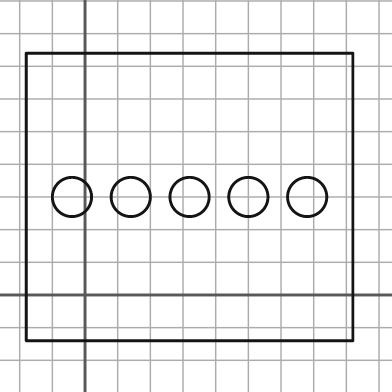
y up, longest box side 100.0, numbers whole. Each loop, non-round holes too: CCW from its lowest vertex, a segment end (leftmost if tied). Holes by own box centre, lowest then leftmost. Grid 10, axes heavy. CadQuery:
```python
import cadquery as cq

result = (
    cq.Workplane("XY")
    .moveTo(-18.0, -14.0)
    .lineTo(82.0, -14.0)
    .lineTo(82.0, 74.0)
    .lineTo(-18.0, 74.0)
    .close()
    .moveTo(-4.0, 30.0)
    .circle(6.0)
    .moveTo(14.0, 30.0)
    .circle(6.0)
    .moveTo(32.0, 30.0)
    .circle(6.0)
    .moveTo(50.0, 30.0)
    .circle(6.0)
    .moveTo(68.0, 30.0)
    .circle(6.0)
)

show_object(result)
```